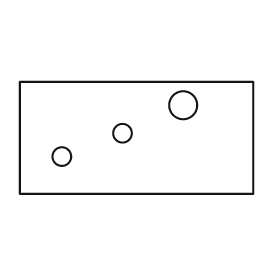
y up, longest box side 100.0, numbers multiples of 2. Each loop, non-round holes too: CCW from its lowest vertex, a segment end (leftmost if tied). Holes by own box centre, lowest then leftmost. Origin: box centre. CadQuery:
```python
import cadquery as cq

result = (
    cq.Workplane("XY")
    .moveTo(-50.0, -24.0)
    .lineTo(50.0, -24.0)
    .lineTo(50.0, 24.0)
    .lineTo(-50.0, 24.0)
    .close()
    .moveTo(-32.0, -8.0)
    .circle(4.0)
    .moveTo(-6.0, 2.0)
    .circle(4.0)
    .moveTo(20.0, 14.0)
    .circle(6.0)
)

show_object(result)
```